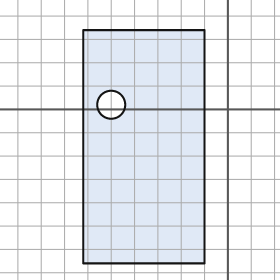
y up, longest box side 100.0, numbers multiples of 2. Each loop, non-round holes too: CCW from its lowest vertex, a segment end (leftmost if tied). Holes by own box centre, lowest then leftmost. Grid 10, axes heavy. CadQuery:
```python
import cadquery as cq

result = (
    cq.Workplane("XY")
    .moveTo(-62.0, -66.0)
    .lineTo(-10.0, -66.0)
    .lineTo(-10.0, 34.0)
    .lineTo(-62.0, 34.0)
    .close()
    .moveTo(-50.0, 2.0)
    .circle(6.0)
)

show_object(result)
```